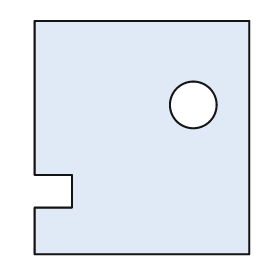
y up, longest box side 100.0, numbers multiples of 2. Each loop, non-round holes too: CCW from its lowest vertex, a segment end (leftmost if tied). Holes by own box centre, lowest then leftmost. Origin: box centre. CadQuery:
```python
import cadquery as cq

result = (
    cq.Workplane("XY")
    .moveTo(-46.0, -50.0)
    .lineTo(46.0, -50.0)
    .lineTo(46.0, 50.0)
    .lineTo(-46.0, 50.0)
    .lineTo(-46.0, -16.0)
    .lineTo(-30.0, -16.0)
    .lineTo(-30.0, -30.0)
    .lineTo(-46.0, -30.0)
    .close()
    .moveTo(22.0, 14.0)
    .circle(10.0)
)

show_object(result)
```